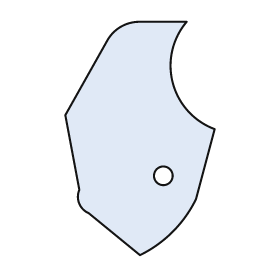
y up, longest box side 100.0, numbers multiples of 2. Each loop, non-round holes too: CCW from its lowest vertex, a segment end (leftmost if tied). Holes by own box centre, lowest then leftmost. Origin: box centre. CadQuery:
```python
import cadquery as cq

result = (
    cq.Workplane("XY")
    .moveTo(0.0, -50.0)
    .threePointArc((14.0, -40.0), (24.0, -26.0))
    .lineTo(32.0, 4.0)
    .threePointArc((14.0, 24.0), (20.0, 50.0))
    .lineTo(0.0, 50.0)
    .threePointArc((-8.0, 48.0), (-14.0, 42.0))
    .lineTo(-32.0, 10.0)
    .lineTo(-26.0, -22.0)
    .threePointArc((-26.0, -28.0), (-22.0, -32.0))
    .close()
    .moveTo(10.0, -16.0)
    .circle(4.0)
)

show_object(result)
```